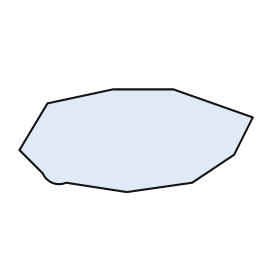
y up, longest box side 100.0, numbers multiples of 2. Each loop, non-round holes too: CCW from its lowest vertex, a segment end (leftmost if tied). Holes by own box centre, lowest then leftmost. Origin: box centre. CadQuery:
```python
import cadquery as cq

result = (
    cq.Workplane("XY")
    .moveTo(-4.0, -22.0)
    .lineTo(24.0, -18.0)
    .lineTo(42.0, -6.0)
    .lineTo(50.0, 10.0)
    .lineTo(16.0, 22.0)
    .lineTo(-10.0, 22.0)
    .lineTo(-38.0, 16.0)
    .lineTo(-50.0, -4.0)
    .lineTo(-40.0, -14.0)
    .threePointArc((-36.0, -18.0), (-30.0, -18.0))
    .close()
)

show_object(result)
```